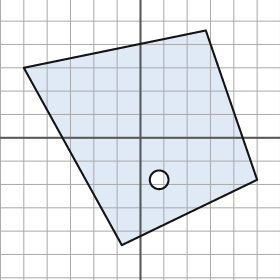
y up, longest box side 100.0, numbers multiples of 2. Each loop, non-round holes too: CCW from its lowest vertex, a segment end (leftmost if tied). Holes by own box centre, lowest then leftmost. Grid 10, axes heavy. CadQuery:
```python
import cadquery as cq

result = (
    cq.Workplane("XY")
    .moveTo(-8.0, -46.0)
    .lineTo(50.0, -18.0)
    .lineTo(28.0, 46.0)
    .lineTo(-50.0, 30.0)
    .close()
    .moveTo(8.0, -18.0)
    .circle(4.0)
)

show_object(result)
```